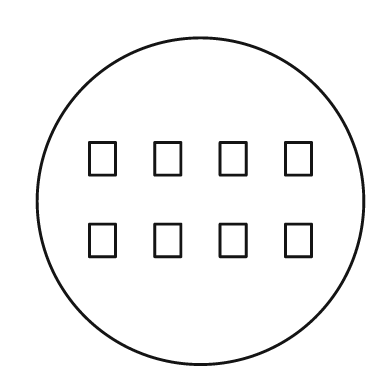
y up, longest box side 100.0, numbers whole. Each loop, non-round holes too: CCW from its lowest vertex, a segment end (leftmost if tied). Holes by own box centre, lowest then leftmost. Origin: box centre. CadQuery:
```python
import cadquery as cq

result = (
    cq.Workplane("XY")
    .moveTo(0.0, 0.0)
    .circle(50.0)
    .moveTo(-34.0, -17.0)
    .lineTo(-26.0, -17.0)
    .lineTo(-26.0, -7.0)
    .lineTo(-34.0, -7.0)
    .close()
    .moveTo(-14.0, -17.0)
    .lineTo(-6.0, -17.0)
    .lineTo(-6.0, -7.0)
    .lineTo(-14.0, -7.0)
    .close()
    .moveTo(6.0, -17.0)
    .lineTo(14.0, -17.0)
    .lineTo(14.0, -7.0)
    .lineTo(6.0, -7.0)
    .close()
    .moveTo(26.0, -17.0)
    .lineTo(34.0, -17.0)
    .lineTo(34.0, -7.0)
    .lineTo(26.0, -7.0)
    .close()
    .moveTo(-34.0, 8.0)
    .lineTo(-26.0, 8.0)
    .lineTo(-26.0, 18.0)
    .lineTo(-34.0, 18.0)
    .close()
    .moveTo(-14.0, 8.0)
    .lineTo(-6.0, 8.0)
    .lineTo(-6.0, 18.0)
    .lineTo(-14.0, 18.0)
    .close()
    .moveTo(6.0, 8.0)
    .lineTo(14.0, 8.0)
    .lineTo(14.0, 18.0)
    .lineTo(6.0, 18.0)
    .close()
    .moveTo(26.0, 8.0)
    .lineTo(34.0, 8.0)
    .lineTo(34.0, 18.0)
    .lineTo(26.0, 18.0)
    .close()
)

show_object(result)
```